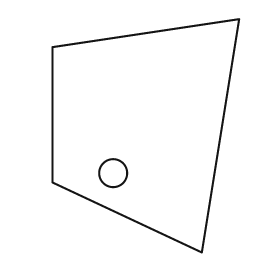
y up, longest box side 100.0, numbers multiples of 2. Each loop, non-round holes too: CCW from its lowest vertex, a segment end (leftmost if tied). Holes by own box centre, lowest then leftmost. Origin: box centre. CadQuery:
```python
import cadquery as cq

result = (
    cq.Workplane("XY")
    .moveTo(24.0, -50.0)
    .lineTo(40.0, 50.0)
    .lineTo(-40.0, 38.0)
    .lineTo(-40.0, -20.0)
    .close()
    .moveTo(-14.0, -16.0)
    .circle(6.0)
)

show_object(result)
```